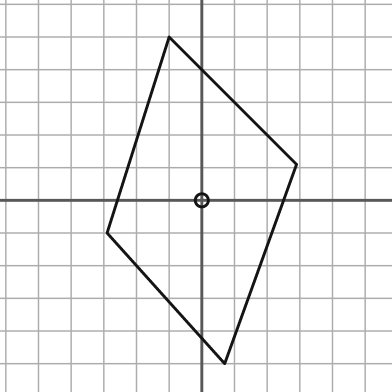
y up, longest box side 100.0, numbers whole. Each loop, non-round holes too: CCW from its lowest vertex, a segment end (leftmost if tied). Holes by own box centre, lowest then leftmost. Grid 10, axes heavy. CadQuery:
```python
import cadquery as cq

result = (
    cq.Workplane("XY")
    .moveTo(7.0, -50.0)
    .lineTo(29.0, 11.0)
    .lineTo(-10.0, 50.0)
    .lineTo(-29.0, -10.0)
    .close()
    .moveTo(0.0, 0.0)
    .circle(2.0)
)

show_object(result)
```